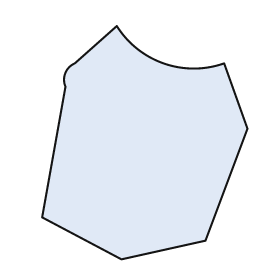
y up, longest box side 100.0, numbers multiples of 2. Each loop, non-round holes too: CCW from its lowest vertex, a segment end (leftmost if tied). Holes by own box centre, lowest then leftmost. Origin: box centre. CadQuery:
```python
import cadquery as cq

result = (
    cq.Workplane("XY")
    .moveTo(-10.0, -50.0)
    .lineTo(26.0, -42.0)
    .lineTo(44.0, 6.0)
    .lineTo(34.0, 34.0)
    .threePointArc((8.0, 34.0), (-12.0, 50.0))
    .lineTo(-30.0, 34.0)
    .threePointArc((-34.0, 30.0), (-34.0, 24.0))
    .lineTo(-44.0, -32.0)
    .close()
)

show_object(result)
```